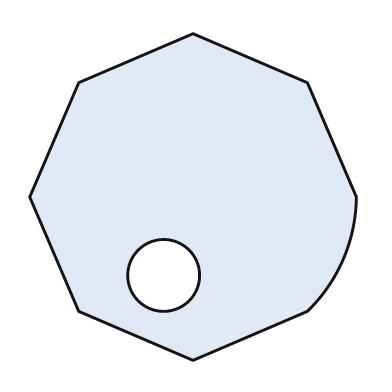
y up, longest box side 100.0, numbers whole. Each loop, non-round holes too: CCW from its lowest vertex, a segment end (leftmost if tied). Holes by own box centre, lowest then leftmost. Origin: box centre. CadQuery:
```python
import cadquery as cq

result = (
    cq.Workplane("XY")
    .moveTo(0.0, -50.0)
    .lineTo(35.0, -35.0)
    .threePointArc((46.0, -19.0), (50.0, 0.0))
    .lineTo(35.0, 35.0)
    .lineTo(0.0, 50.0)
    .lineTo(-35.0, 35.0)
    .lineTo(-50.0, 0.0)
    .lineTo(-35.0, -35.0)
    .close()
    .moveTo(-9.0, -24.0)
    .circle(11.0)
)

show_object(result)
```